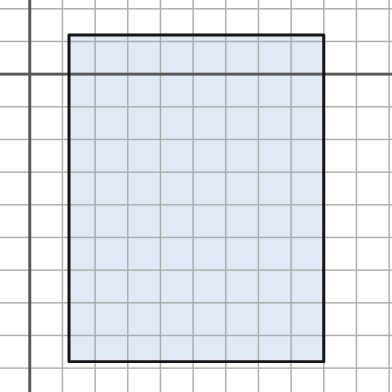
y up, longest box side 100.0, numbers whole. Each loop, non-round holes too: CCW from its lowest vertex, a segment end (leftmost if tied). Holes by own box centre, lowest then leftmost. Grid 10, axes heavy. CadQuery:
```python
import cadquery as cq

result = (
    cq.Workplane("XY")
    .moveTo(12.0, -88.0)
    .lineTo(90.0, -88.0)
    .lineTo(90.0, 12.0)
    .lineTo(12.0, 12.0)
    .close()
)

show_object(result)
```